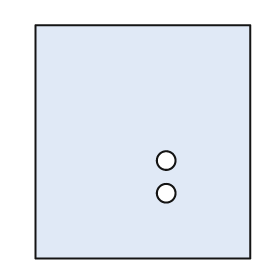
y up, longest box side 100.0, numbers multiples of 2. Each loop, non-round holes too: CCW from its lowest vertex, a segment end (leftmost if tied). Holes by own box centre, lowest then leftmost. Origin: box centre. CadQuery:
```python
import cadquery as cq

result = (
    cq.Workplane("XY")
    .moveTo(-46.0, -50.0)
    .lineTo(46.0, -50.0)
    .lineTo(46.0, 50.0)
    .lineTo(-46.0, 50.0)
    .close()
    .moveTo(10.0, -22.0)
    .circle(4.0)
    .moveTo(10.0, -8.0)
    .circle(4.0)
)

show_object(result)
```